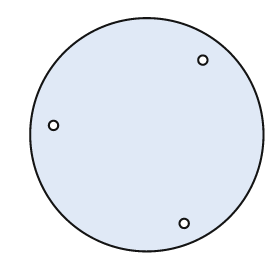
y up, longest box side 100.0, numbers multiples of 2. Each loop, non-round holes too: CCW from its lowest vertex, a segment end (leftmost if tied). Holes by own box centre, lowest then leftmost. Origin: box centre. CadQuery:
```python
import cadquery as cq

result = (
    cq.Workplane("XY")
    .moveTo(0.0, 0.0)
    .circle(50.0)
    .moveTo(16.0, -38.0)
    .circle(2.0)
    .moveTo(-40.0, 4.0)
    .circle(2.0)
    .moveTo(24.0, 32.0)
    .circle(2.0)
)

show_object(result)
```